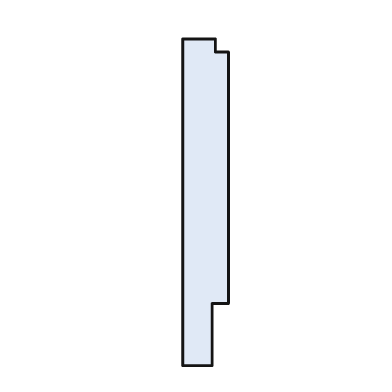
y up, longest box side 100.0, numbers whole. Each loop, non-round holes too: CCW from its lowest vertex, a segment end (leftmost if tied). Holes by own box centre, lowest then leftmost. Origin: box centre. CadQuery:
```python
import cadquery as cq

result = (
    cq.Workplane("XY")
    .moveTo(-7.0, -50.0)
    .lineTo(2.0, -50.0)
    .lineTo(2.0, -31.0)
    .lineTo(7.0, -31.0)
    .lineTo(7.0, 46.0)
    .lineTo(3.0, 46.0)
    .lineTo(3.0, 50.0)
    .lineTo(-7.0, 50.0)
    .close()
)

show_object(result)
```